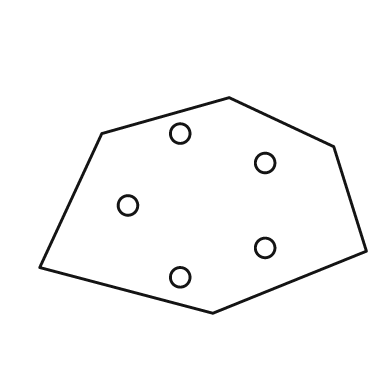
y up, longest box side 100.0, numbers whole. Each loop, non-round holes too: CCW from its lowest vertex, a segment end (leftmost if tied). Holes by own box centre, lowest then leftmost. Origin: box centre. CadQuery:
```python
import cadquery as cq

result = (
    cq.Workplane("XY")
    .moveTo(3.0, -33.0)
    .lineTo(50.0, -14.0)
    .lineTo(40.0, 18.0)
    .lineTo(8.0, 33.0)
    .lineTo(-31.0, 22.0)
    .lineTo(-50.0, -19.0)
    .close()
    .moveTo(-7.0, -22.0)
    .circle(3.0)
    .moveTo(19.0, -13.0)
    .circle(3.0)
    .moveTo(-23.0, 0.0)
    .circle(3.0)
    .moveTo(19.0, 13.0)
    .circle(3.0)
    .moveTo(-7.0, 22.0)
    .circle(3.0)
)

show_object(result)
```